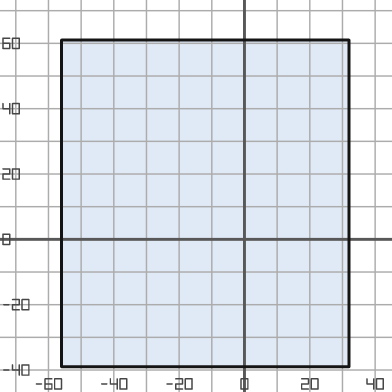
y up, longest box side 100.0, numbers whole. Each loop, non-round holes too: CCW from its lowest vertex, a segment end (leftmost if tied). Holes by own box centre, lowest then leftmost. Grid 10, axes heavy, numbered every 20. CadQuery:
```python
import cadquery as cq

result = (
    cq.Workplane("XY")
    .moveTo(-56.0, -39.0)
    .lineTo(32.0, -39.0)
    .lineTo(32.0, 61.0)
    .lineTo(-56.0, 61.0)
    .close()
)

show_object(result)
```